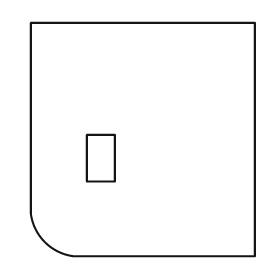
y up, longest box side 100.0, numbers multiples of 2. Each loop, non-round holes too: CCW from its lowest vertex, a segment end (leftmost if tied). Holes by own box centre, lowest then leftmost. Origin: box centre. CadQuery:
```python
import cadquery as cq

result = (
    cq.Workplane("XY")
    .moveTo(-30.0, -50.0)
    .lineTo(48.0, -50.0)
    .lineTo(48.0, 50.0)
    .lineTo(-48.0, 50.0)
    .lineTo(-48.0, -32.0)
    .threePointArc((-42.0, -44.0), (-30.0, -50.0))
    .close()
    .moveTo(-24.0, -18.0)
    .lineTo(-12.0, -18.0)
    .lineTo(-12.0, 2.0)
    .lineTo(-24.0, 2.0)
    .close()
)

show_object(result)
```